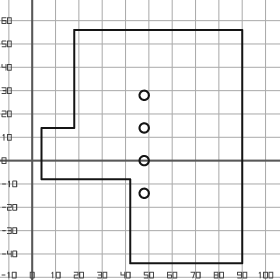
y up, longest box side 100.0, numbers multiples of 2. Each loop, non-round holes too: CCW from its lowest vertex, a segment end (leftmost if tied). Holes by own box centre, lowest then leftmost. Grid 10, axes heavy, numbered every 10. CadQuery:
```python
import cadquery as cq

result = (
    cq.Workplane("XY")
    .moveTo(42.0, -44.0)
    .lineTo(90.0, -44.0)
    .lineTo(90.0, 56.0)
    .lineTo(18.0, 56.0)
    .lineTo(18.0, 14.0)
    .lineTo(4.0, 14.0)
    .lineTo(4.0, -8.0)
    .lineTo(42.0, -8.0)
    .close()
    .moveTo(48.0, -14.0)
    .circle(2.0)
    .moveTo(48.0, 0.0)
    .circle(2.0)
    .moveTo(48.0, 14.0)
    .circle(2.0)
    .moveTo(48.0, 28.0)
    .circle(2.0)
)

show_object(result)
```